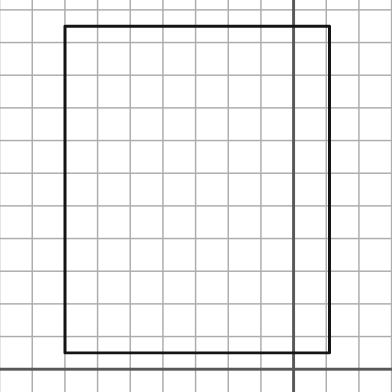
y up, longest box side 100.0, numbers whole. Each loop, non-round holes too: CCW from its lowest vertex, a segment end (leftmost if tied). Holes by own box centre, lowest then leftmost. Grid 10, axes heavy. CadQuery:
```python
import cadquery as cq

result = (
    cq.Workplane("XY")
    .moveTo(-70.0, 5.0)
    .lineTo(11.0, 5.0)
    .lineTo(11.0, 105.0)
    .lineTo(-70.0, 105.0)
    .close()
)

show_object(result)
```